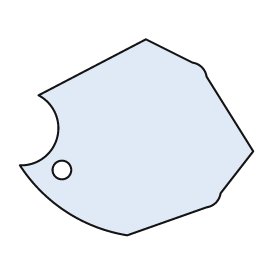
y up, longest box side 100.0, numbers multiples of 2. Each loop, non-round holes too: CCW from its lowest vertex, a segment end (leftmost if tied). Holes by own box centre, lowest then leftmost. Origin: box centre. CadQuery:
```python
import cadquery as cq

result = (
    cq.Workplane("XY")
    .moveTo(-4.0, -42.0)
    .lineTo(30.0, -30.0)
    .threePointArc((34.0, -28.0), (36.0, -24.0))
    .lineTo(50.0, -6.0)
    .lineTo(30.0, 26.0)
    .threePointArc((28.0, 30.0), (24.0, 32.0))
    .lineTo(4.0, 42.0)
    .lineTo(-42.0, 18.0)
    .threePointArc((-34.0, 0.0), (-50.0, -12.0))
    .threePointArc((-30.0, -32.0), (-4.0, -42.0))
    .close()
    .moveTo(-32.0, -14.0)
    .circle(4.0)
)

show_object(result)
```